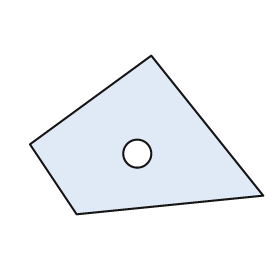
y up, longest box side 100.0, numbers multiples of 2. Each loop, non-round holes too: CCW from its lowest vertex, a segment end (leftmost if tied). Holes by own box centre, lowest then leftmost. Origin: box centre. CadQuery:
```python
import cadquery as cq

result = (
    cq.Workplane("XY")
    .moveTo(-30.0, -34.0)
    .lineTo(50.0, -26.0)
    .lineTo(2.0, 34.0)
    .lineTo(-50.0, -4.0)
    .close()
    .moveTo(-4.0, -8.0)
    .circle(6.0)
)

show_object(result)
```